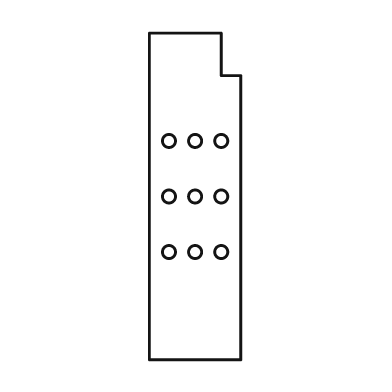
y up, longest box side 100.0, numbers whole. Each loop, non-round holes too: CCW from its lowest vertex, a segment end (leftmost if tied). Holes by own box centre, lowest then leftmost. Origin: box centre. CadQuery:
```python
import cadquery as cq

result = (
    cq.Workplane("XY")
    .moveTo(-14.0, -50.0)
    .lineTo(14.0, -50.0)
    .lineTo(14.0, 37.0)
    .lineTo(8.0, 37.0)
    .lineTo(8.0, 50.0)
    .lineTo(-14.0, 50.0)
    .close()
    .moveTo(-8.0, -17.0)
    .circle(2.0)
    .moveTo(0.0, -17.0)
    .circle(2.0)
    .moveTo(8.0, -17.0)
    .circle(2.0)
    .moveTo(-8.0, 0.0)
    .circle(2.0)
    .moveTo(0.0, 0.0)
    .circle(2.0)
    .moveTo(8.0, 0.0)
    .circle(2.0)
    .moveTo(-8.0, 17.0)
    .circle(2.0)
    .moveTo(0.0, 17.0)
    .circle(2.0)
    .moveTo(8.0, 17.0)
    .circle(2.0)
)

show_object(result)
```